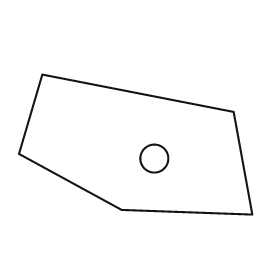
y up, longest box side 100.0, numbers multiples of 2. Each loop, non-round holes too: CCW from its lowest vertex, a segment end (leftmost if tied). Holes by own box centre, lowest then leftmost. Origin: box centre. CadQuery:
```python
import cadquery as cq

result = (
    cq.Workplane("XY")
    .moveTo(50.0, -30.0)
    .lineTo(42.0, 14.0)
    .lineTo(-40.0, 30.0)
    .lineTo(-50.0, -4.0)
    .lineTo(-6.0, -28.0)
    .close()
    .moveTo(8.0, -6.0)
    .circle(6.0)
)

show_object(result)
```